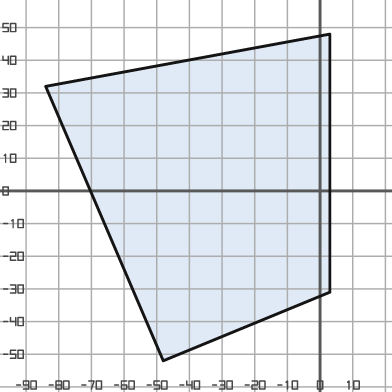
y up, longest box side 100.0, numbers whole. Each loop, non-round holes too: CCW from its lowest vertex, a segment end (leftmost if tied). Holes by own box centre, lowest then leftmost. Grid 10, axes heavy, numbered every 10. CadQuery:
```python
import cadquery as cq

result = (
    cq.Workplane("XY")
    .moveTo(-48.0, -52.0)
    .lineTo(3.0, -31.0)
    .lineTo(3.0, 48.0)
    .lineTo(-84.0, 32.0)
    .close()
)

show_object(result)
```